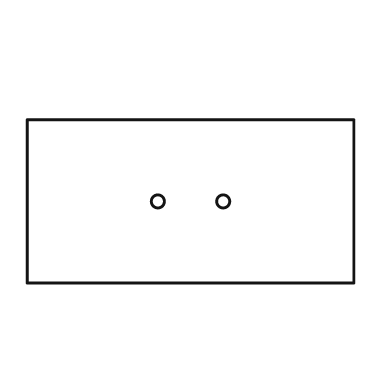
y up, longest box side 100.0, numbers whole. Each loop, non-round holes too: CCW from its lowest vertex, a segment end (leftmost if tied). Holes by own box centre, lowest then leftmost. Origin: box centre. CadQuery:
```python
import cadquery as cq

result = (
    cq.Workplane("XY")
    .moveTo(-50.0, -25.0)
    .lineTo(50.0, -25.0)
    .lineTo(50.0, 25.0)
    .lineTo(-50.0, 25.0)
    .close()
    .moveTo(-10.0, 0.0)
    .circle(2.0)
    .moveTo(10.0, 0.0)
    .circle(2.0)
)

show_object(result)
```